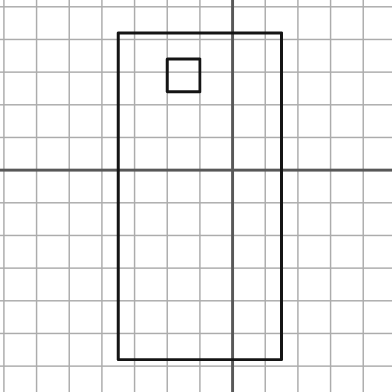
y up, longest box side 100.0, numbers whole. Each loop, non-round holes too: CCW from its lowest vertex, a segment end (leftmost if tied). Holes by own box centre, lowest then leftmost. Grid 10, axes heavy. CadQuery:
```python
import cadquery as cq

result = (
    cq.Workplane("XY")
    .moveTo(-35.0, -58.0)
    .lineTo(15.0, -58.0)
    .lineTo(15.0, 42.0)
    .lineTo(-35.0, 42.0)
    .close()
    .moveTo(-20.0, 24.0)
    .lineTo(-10.0, 24.0)
    .lineTo(-10.0, 34.0)
    .lineTo(-20.0, 34.0)
    .close()
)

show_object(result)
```